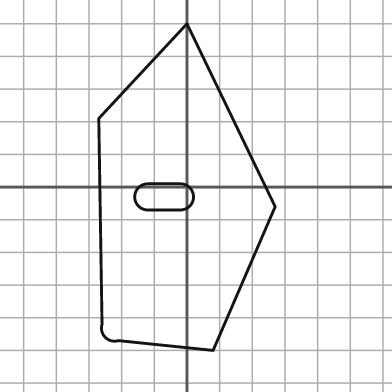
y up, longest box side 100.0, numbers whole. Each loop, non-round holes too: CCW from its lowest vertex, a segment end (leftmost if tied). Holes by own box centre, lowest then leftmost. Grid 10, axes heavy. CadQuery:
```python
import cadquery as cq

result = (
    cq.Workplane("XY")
    .moveTo(8.0, -50.0)
    .lineTo(27.0, -6.0)
    .lineTo(0.0, 50.0)
    .lineTo(-27.0, 21.0)
    .lineTo(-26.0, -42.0)
    .threePointArc((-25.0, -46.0), (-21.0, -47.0))
    .close()
    .moveTo(-12.0, -7.0)
    .lineTo(-2.0, -7.0)
    .threePointArc((2.0, -3.0), (-2.0, 1.0))
    .lineTo(-12.0, 1.0)
    .threePointArc((-16.0, -3.0), (-12.0, -7.0))
    .close()
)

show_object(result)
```